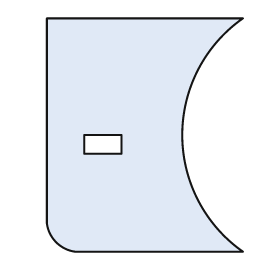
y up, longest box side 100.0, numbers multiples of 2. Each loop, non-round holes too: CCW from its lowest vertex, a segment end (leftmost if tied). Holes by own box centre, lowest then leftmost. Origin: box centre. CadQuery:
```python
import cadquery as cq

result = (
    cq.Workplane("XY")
    .moveTo(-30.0, -50.0)
    .lineTo(42.0, -50.0)
    .threePointArc((16.0, 0.0), (42.0, 50.0))
    .lineTo(-42.0, 50.0)
    .lineTo(-42.0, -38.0)
    .threePointArc((-38.0, -46.0), (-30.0, -50.0))
    .close()
    .moveTo(-26.0, -8.0)
    .lineTo(-10.0, -8.0)
    .lineTo(-10.0, 0.0)
    .lineTo(-26.0, 0.0)
    .close()
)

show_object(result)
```